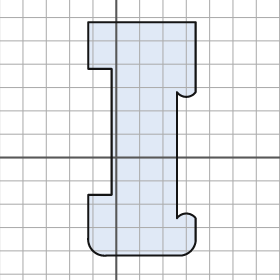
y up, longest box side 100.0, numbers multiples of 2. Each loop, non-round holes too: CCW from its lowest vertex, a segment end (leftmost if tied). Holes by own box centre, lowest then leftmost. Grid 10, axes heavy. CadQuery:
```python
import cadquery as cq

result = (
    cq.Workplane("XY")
    .moveTo(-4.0, -42.0)
    .lineTo(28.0, -42.0)
    .threePointArc((32.0, -40.0), (34.0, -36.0))
    .lineTo(34.0, -26.0)
    .threePointArc((30.0, -24.0), (26.0, -26.0))
    .lineTo(26.0, 28.0)
    .threePointArc((30.0, 26.0), (34.0, 28.0))
    .lineTo(34.0, 58.0)
    .lineTo(-12.0, 58.0)
    .lineTo(-12.0, 38.0)
    .lineTo(-2.0, 38.0)
    .lineTo(-2.0, -16.0)
    .lineTo(-12.0, -16.0)
    .lineTo(-12.0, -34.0)
    .threePointArc((-10.0, -40.0), (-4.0, -42.0))
    .close()
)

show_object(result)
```